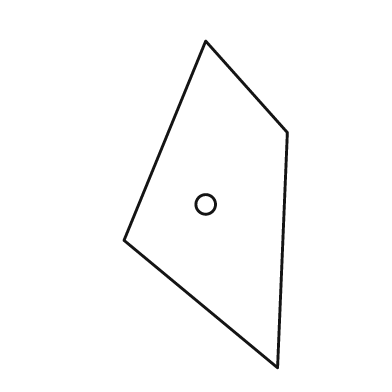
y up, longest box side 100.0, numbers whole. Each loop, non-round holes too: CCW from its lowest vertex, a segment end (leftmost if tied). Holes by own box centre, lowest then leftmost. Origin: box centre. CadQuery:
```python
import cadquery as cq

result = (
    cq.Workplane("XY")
    .moveTo(22.0, -50.0)
    .lineTo(25.0, 22.0)
    .lineTo(0.0, 50.0)
    .lineTo(-25.0, -11.0)
    .close()
    .moveTo(0.0, 0.0)
    .circle(3.0)
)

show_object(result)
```